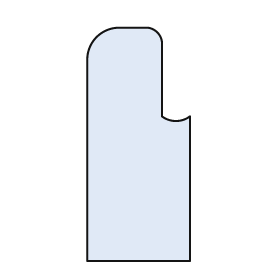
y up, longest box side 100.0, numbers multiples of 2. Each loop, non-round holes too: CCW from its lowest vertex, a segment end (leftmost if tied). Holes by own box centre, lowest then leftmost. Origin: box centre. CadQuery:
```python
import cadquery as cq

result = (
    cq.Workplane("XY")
    .moveTo(-22.0, -50.0)
    .lineTo(22.0, -50.0)
    .lineTo(22.0, 12.0)
    .threePointArc((16.0, 10.0), (10.0, 12.0))
    .lineTo(10.0, 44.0)
    .threePointArc((8.0, 48.0), (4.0, 50.0))
    .lineTo(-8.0, 50.0)
    .threePointArc((-18.0, 46.0), (-22.0, 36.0))
    .close()
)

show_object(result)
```